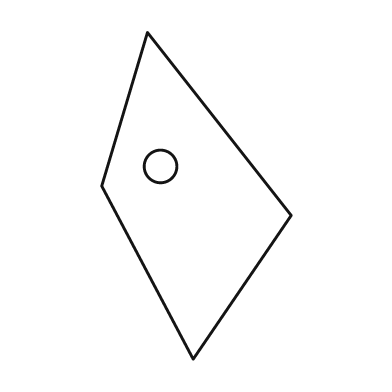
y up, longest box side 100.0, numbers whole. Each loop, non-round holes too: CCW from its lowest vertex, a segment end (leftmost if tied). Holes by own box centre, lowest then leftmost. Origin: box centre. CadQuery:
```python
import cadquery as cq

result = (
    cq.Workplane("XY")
    .moveTo(-1.0, -50.0)
    .lineTo(29.0, -6.0)
    .lineTo(-15.0, 50.0)
    .lineTo(-29.0, 3.0)
    .close()
    .moveTo(-11.0, 9.0)
    .circle(5.0)
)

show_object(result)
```